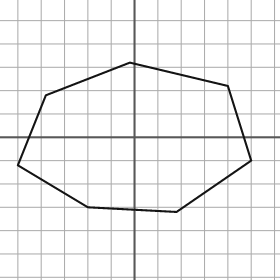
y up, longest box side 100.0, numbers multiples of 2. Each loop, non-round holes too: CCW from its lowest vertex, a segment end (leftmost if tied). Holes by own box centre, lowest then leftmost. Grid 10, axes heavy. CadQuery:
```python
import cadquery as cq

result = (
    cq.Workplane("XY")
    .moveTo(18.0, -32.0)
    .lineTo(50.0, -10.0)
    .lineTo(40.0, 22.0)
    .lineTo(-2.0, 32.0)
    .lineTo(-38.0, 18.0)
    .lineTo(-50.0, -12.0)
    .lineTo(-20.0, -30.0)
    .close()
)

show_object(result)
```